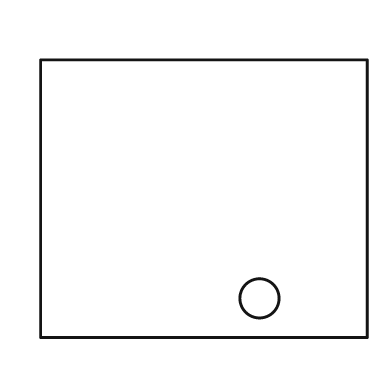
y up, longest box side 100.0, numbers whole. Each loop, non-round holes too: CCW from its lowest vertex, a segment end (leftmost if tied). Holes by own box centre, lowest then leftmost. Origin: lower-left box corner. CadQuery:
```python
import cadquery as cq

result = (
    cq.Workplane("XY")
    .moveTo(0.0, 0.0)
    .lineTo(100.0, 0.0)
    .lineTo(100.0, 85.0)
    .lineTo(0.0, 85.0)
    .close()
    .moveTo(67.0, 12.0)
    .circle(6.0)
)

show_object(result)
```